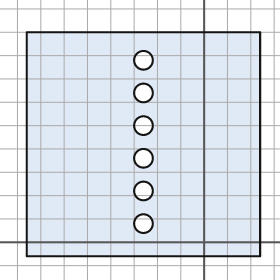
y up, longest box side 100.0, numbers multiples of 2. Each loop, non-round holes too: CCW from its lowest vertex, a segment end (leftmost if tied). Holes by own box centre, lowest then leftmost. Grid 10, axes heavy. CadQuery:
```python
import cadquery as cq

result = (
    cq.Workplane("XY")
    .moveTo(-76.0, -6.0)
    .lineTo(24.0, -6.0)
    .lineTo(24.0, 90.0)
    .lineTo(-76.0, 90.0)
    .close()
    .moveTo(-26.0, 8.0)
    .circle(4.0)
    .moveTo(-26.0, 22.0)
    .circle(4.0)
    .moveTo(-26.0, 36.0)
    .circle(4.0)
    .moveTo(-26.0, 50.0)
    .circle(4.0)
    .moveTo(-26.0, 64.0)
    .circle(4.0)
    .moveTo(-26.0, 78.0)
    .circle(4.0)
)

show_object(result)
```